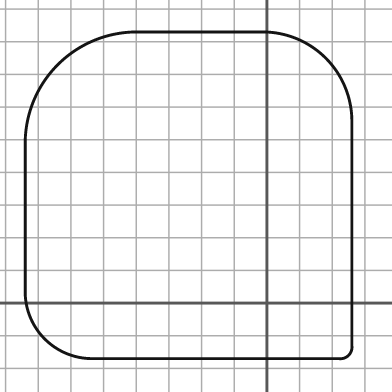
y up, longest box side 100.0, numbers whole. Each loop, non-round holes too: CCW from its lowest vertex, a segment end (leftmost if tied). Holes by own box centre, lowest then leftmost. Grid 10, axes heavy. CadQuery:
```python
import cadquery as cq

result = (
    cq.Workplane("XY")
    .moveTo(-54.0, -17.0)
    .lineTo(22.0, -17.0)
    .threePointArc((25.0, -16.0), (26.0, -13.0))
    .lineTo(26.0, 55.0)
    .threePointArc((18.0, 75.0), (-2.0, 83.0))
    .lineTo(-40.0, 83.0)
    .threePointArc((-64.0, 73.0), (-74.0, 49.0))
    .lineTo(-74.0, 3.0)
    .threePointArc((-68.0, -11.0), (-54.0, -17.0))
    .close()
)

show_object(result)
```